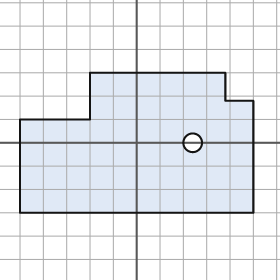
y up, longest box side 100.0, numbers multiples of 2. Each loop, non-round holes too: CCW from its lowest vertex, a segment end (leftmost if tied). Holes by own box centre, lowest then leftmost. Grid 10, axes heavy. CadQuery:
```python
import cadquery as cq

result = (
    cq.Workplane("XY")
    .moveTo(-50.0, -30.0)
    .lineTo(50.0, -30.0)
    .lineTo(50.0, 18.0)
    .lineTo(38.0, 18.0)
    .lineTo(38.0, 30.0)
    .lineTo(-20.0, 30.0)
    .lineTo(-20.0, 10.0)
    .lineTo(-50.0, 10.0)
    .close()
    .moveTo(24.0, 0.0)
    .circle(4.0)
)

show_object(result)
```